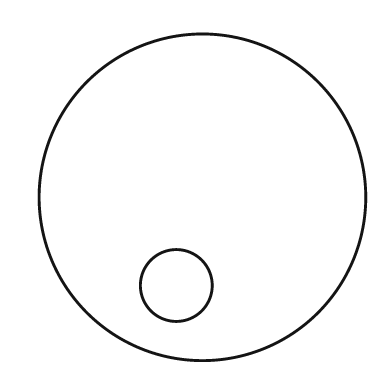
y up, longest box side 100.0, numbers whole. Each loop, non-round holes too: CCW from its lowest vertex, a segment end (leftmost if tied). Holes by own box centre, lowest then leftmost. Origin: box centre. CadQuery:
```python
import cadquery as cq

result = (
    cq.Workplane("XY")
    .moveTo(0.0, 0.0)
    .circle(50.0)
    .moveTo(-8.0, -27.0)
    .circle(11.0)
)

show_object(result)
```